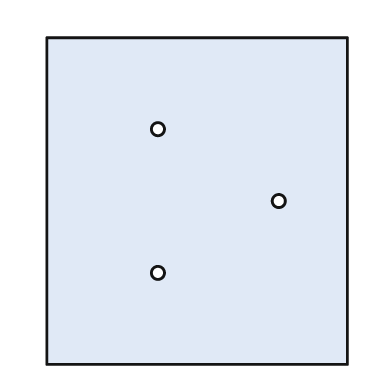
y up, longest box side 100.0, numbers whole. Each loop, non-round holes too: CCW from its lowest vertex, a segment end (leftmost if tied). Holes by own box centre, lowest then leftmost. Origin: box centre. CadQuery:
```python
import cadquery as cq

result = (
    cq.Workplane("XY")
    .moveTo(-46.0, -50.0)
    .lineTo(46.0, -50.0)
    .lineTo(46.0, 50.0)
    .lineTo(-46.0, 50.0)
    .close()
    .moveTo(-12.0, -22.0)
    .circle(2.0)
    .moveTo(25.0, 0.0)
    .circle(2.0)
    .moveTo(-12.0, 22.0)
    .circle(2.0)
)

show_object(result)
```